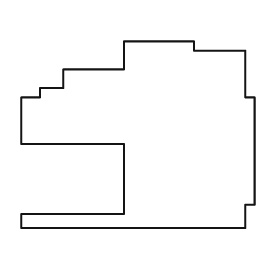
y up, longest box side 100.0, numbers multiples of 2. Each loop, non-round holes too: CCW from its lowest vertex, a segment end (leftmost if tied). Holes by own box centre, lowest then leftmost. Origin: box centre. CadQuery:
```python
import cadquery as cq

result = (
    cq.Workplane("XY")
    .moveTo(-50.0, -40.0)
    .lineTo(46.0, -40.0)
    .lineTo(46.0, -30.0)
    .lineTo(50.0, -30.0)
    .lineTo(50.0, 16.0)
    .lineTo(46.0, 16.0)
    .lineTo(46.0, 36.0)
    .lineTo(24.0, 36.0)
    .lineTo(24.0, 40.0)
    .lineTo(-6.0, 40.0)
    .lineTo(-6.0, 28.0)
    .lineTo(-32.0, 28.0)
    .lineTo(-32.0, 20.0)
    .lineTo(-42.0, 20.0)
    .lineTo(-42.0, 16.0)
    .lineTo(-50.0, 16.0)
    .lineTo(-50.0, -4.0)
    .lineTo(-6.0, -4.0)
    .lineTo(-6.0, -34.0)
    .lineTo(-50.0, -34.0)
    .close()
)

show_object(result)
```